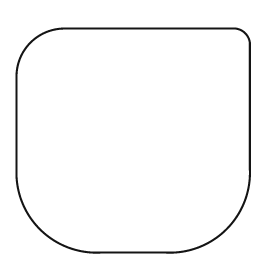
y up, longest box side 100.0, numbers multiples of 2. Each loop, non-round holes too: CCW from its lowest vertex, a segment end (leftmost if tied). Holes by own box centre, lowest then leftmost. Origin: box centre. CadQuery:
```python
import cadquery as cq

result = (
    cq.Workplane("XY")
    .moveTo(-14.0, -48.0)
    .lineTo(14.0, -48.0)
    .threePointArc((40.0, -38.0), (50.0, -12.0))
    .lineTo(50.0, 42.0)
    .threePointArc((48.0, 46.0), (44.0, 48.0))
    .lineTo(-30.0, 48.0)
    .threePointArc((-44.0, 42.0), (-50.0, 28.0))
    .lineTo(-50.0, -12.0)
    .threePointArc((-40.0, -38.0), (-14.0, -48.0))
    .close()
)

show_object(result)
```